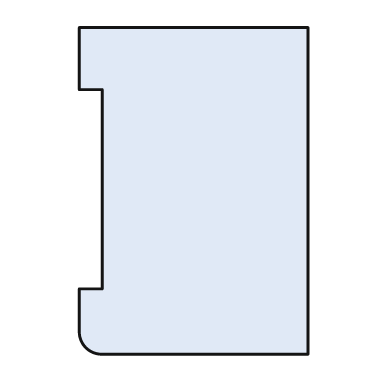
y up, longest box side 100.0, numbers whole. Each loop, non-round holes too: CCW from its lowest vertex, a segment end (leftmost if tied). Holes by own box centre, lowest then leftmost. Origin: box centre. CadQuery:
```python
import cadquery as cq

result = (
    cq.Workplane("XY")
    .moveTo(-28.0, -50.0)
    .lineTo(35.0, -50.0)
    .lineTo(35.0, 50.0)
    .lineTo(-35.0, 50.0)
    .lineTo(-35.0, 31.0)
    .lineTo(-28.0, 31.0)
    .lineTo(-28.0, -30.0)
    .lineTo(-35.0, -30.0)
    .lineTo(-35.0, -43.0)
    .threePointArc((-33.0, -48.0), (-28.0, -50.0))
    .close()
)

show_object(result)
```